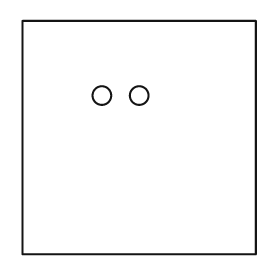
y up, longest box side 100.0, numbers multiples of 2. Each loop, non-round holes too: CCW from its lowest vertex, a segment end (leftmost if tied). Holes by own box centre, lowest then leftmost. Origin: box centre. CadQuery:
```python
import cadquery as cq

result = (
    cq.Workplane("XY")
    .moveTo(-50.0, -50.0)
    .lineTo(50.0, -50.0)
    .lineTo(50.0, 50.0)
    .lineTo(-50.0, 50.0)
    .close()
    .moveTo(-16.0, 18.0)
    .circle(4.0)
    .moveTo(0.0, 18.0)
    .circle(4.0)
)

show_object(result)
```